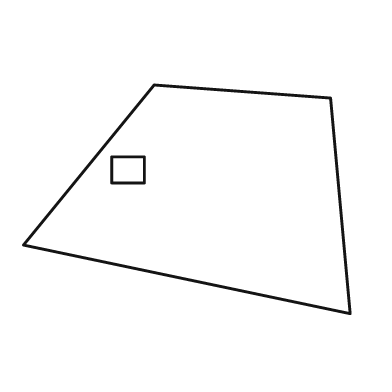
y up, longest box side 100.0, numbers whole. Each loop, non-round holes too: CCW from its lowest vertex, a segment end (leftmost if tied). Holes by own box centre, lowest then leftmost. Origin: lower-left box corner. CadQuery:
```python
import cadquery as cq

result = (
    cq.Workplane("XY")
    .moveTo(100.0, 0.0)
    .lineTo(94.0, 66.0)
    .lineTo(40.0, 70.0)
    .lineTo(0.0, 21.0)
    .close()
    .moveTo(27.0, 40.0)
    .lineTo(37.0, 40.0)
    .lineTo(37.0, 48.0)
    .lineTo(27.0, 48.0)
    .close()
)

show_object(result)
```